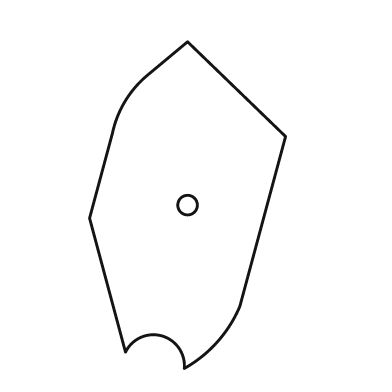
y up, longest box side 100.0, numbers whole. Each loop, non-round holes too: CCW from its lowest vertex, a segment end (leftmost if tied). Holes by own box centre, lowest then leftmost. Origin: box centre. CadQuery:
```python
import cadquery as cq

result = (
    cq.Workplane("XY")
    .moveTo(-1.0, -50.0)
    .threePointArc((9.0, -42.0), (16.0, -31.0))
    .lineTo(30.0, 21.0)
    .lineTo(0.0, 50.0)
    .lineTo(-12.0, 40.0)
    .threePointArc((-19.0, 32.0), (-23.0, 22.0))
    .lineTo(-30.0, -4.0)
    .lineTo(-19.0, -45.0)
    .threePointArc((-8.0, -40.0), (-1.0, -50.0))
    .close()
    .moveTo(0.0, 0.0)
    .circle(3.0)
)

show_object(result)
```